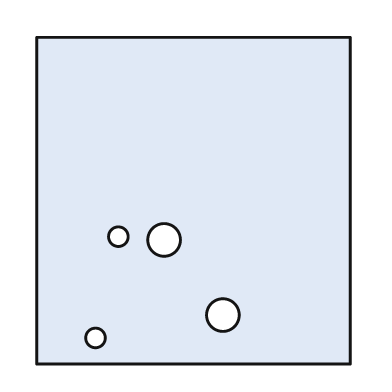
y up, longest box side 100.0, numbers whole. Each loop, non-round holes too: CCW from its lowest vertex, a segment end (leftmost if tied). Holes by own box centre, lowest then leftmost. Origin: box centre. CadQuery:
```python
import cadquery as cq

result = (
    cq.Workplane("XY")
    .moveTo(-48.0, -50.0)
    .lineTo(48.0, -50.0)
    .lineTo(48.0, 50.0)
    .lineTo(-48.0, 50.0)
    .close()
    .moveTo(-30.0, -42.0)
    .circle(3.0)
    .moveTo(9.0, -35.0)
    .circle(5.0)
    .moveTo(-9.0, -12.0)
    .circle(5.0)
    .moveTo(-23.0, -11.0)
    .circle(3.0)
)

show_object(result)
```